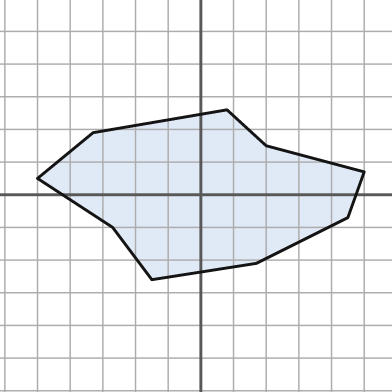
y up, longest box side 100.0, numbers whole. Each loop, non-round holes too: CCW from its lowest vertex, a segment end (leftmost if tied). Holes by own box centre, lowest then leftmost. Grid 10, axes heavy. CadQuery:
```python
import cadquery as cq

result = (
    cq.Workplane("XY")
    .moveTo(-15.0, -26.0)
    .lineTo(17.0, -21.0)
    .lineTo(45.0, -7.0)
    .lineTo(50.0, 7.0)
    .lineTo(20.0, 15.0)
    .lineTo(8.0, 26.0)
    .lineTo(-33.0, 19.0)
    .lineTo(-50.0, 5.0)
    .lineTo(-27.0, -10.0)
    .close()
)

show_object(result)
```